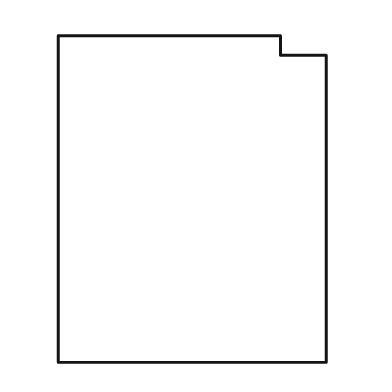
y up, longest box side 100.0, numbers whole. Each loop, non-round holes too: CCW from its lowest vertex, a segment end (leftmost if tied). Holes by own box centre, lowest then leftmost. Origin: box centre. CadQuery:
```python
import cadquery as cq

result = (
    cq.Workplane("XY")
    .moveTo(-41.0, -50.0)
    .lineTo(41.0, -50.0)
    .lineTo(41.0, 44.0)
    .lineTo(27.0, 44.0)
    .lineTo(27.0, 50.0)
    .lineTo(-41.0, 50.0)
    .close()
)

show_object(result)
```